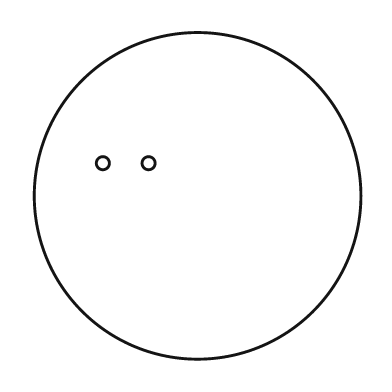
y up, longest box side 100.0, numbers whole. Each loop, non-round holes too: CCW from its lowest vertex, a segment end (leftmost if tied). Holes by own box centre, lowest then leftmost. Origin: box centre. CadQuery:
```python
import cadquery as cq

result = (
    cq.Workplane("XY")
    .moveTo(0.0, 0.0)
    .circle(50.0)
    .moveTo(-29.0, 10.0)
    .circle(2.0)
    .moveTo(-15.0, 10.0)
    .circle(2.0)
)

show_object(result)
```